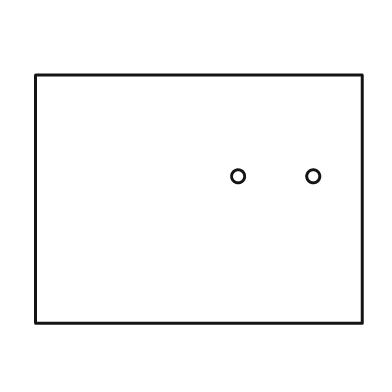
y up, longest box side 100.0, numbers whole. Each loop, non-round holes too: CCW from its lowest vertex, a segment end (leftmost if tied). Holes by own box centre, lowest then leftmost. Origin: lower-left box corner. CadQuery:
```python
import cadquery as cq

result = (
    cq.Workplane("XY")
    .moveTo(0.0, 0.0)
    .lineTo(100.0, 0.0)
    .lineTo(100.0, 76.0)
    .lineTo(0.0, 76.0)
    .close()
    .moveTo(62.0, 45.0)
    .circle(2.0)
    .moveTo(85.0, 45.0)
    .circle(2.0)
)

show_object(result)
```